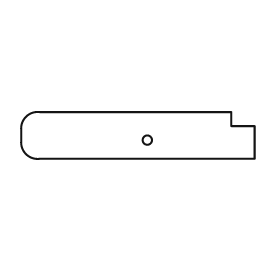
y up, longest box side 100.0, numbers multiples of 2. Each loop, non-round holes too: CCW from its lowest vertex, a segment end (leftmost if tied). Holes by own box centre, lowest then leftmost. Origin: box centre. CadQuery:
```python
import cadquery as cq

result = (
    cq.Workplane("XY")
    .moveTo(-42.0, -10.0)
    .lineTo(50.0, -10.0)
    .lineTo(50.0, 4.0)
    .lineTo(40.0, 4.0)
    .lineTo(40.0, 10.0)
    .lineTo(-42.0, 10.0)
    .threePointArc((-48.0, 8.0), (-50.0, 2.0))
    .lineTo(-50.0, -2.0)
    .threePointArc((-48.0, -8.0), (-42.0, -10.0))
    .close()
    .moveTo(4.0, -2.0)
    .circle(2.0)
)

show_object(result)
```